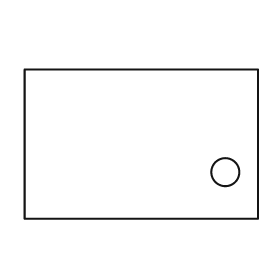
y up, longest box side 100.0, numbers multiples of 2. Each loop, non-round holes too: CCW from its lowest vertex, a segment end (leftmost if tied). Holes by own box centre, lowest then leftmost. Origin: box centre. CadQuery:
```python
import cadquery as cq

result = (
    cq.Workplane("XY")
    .moveTo(-50.0, -32.0)
    .lineTo(50.0, -32.0)
    .lineTo(50.0, 32.0)
    .lineTo(-50.0, 32.0)
    .close()
    .moveTo(36.0, -12.0)
    .circle(6.0)
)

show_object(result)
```